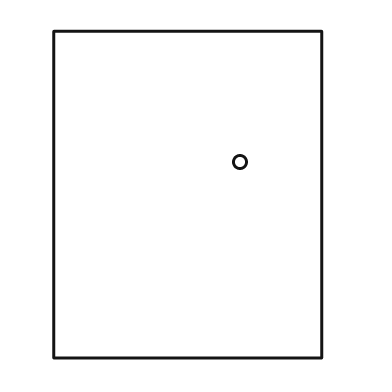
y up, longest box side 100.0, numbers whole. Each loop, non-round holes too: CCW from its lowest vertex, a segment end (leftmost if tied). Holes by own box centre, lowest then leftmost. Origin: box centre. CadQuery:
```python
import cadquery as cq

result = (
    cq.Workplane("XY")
    .moveTo(-41.0, -50.0)
    .lineTo(41.0, -50.0)
    .lineTo(41.0, 50.0)
    .lineTo(-41.0, 50.0)
    .close()
    .moveTo(16.0, 10.0)
    .circle(2.0)
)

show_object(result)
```